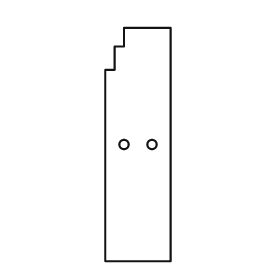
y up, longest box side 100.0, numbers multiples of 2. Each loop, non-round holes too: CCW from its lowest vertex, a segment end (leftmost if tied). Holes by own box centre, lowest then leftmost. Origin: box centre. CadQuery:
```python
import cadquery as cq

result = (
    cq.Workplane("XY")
    .moveTo(-14.0, -50.0)
    .lineTo(14.0, -50.0)
    .lineTo(14.0, 50.0)
    .lineTo(-6.0, 50.0)
    .lineTo(-6.0, 42.0)
    .lineTo(-10.0, 42.0)
    .lineTo(-10.0, 32.0)
    .lineTo(-14.0, 32.0)
    .close()
    .moveTo(-6.0, 0.0)
    .circle(2.0)
    .moveTo(6.0, 0.0)
    .circle(2.0)
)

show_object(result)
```